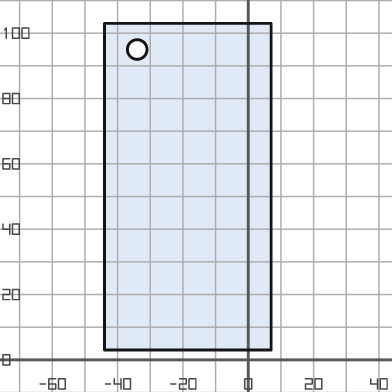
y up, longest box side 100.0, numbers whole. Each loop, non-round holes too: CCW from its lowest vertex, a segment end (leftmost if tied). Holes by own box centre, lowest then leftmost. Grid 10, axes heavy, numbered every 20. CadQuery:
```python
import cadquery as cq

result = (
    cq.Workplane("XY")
    .moveTo(-44.0, 3.0)
    .lineTo(7.0, 3.0)
    .lineTo(7.0, 103.0)
    .lineTo(-44.0, 103.0)
    .close()
    .moveTo(-34.0, 95.0)
    .circle(3.0)
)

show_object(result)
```